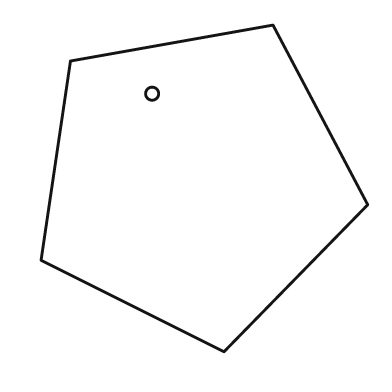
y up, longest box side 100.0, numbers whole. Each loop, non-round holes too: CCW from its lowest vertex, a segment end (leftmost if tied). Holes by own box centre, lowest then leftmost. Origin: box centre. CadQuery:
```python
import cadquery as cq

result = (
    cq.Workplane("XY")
    .moveTo(6.0, -50.0)
    .lineTo(50.0, -5.0)
    .lineTo(21.0, 50.0)
    .lineTo(-41.0, 39.0)
    .lineTo(-50.0, -22.0)
    .close()
    .moveTo(-16.0, 29.0)
    .circle(2.0)
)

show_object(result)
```